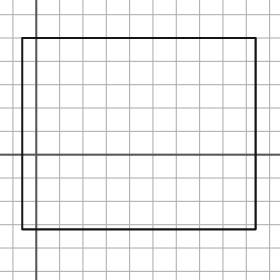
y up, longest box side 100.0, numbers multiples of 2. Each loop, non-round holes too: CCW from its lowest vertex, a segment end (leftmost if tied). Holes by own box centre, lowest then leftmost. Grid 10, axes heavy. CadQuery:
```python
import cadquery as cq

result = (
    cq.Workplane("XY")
    .moveTo(-6.0, -32.0)
    .lineTo(94.0, -32.0)
    .lineTo(94.0, 50.0)
    .lineTo(-6.0, 50.0)
    .close()
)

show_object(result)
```